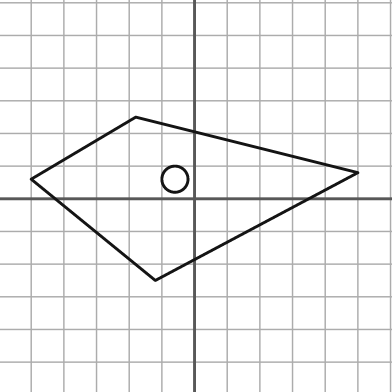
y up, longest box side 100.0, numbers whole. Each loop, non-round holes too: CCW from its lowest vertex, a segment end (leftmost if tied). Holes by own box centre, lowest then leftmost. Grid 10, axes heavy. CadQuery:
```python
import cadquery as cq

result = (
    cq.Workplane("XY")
    .moveTo(-12.0, -25.0)
    .lineTo(50.0, 8.0)
    .lineTo(-18.0, 25.0)
    .lineTo(-50.0, 6.0)
    .close()
    .moveTo(-6.0, 6.0)
    .circle(4.0)
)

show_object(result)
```